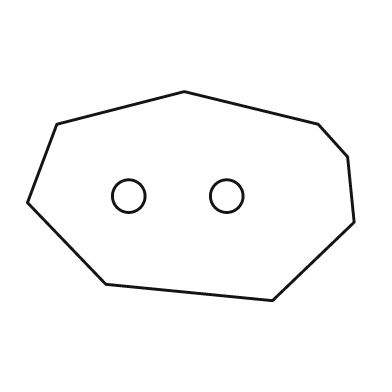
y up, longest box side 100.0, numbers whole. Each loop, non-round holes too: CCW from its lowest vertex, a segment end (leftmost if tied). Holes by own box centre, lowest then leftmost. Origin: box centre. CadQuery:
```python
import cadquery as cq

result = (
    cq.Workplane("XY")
    .moveTo(25.0, -32.0)
    .lineTo(50.0, -8.0)
    .lineTo(48.0, 12.0)
    .lineTo(39.0, 22.0)
    .lineTo(-2.0, 32.0)
    .lineTo(-41.0, 22.0)
    .lineTo(-50.0, -2.0)
    .lineTo(-26.0, -27.0)
    .close()
    .moveTo(-19.0, 0.0)
    .circle(5.0)
    .moveTo(11.0, 0.0)
    .circle(5.0)
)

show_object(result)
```